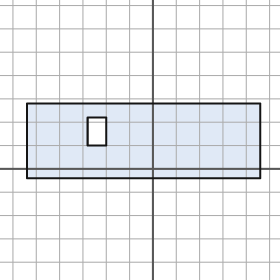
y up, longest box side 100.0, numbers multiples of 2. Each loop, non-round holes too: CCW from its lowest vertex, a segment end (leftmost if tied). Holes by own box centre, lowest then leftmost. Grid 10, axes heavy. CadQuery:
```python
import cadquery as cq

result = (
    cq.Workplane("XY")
    .moveTo(-54.0, -4.0)
    .lineTo(46.0, -4.0)
    .lineTo(46.0, 28.0)
    .lineTo(-54.0, 28.0)
    .close()
    .moveTo(-28.0, 10.0)
    .lineTo(-20.0, 10.0)
    .lineTo(-20.0, 22.0)
    .lineTo(-28.0, 22.0)
    .close()
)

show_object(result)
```